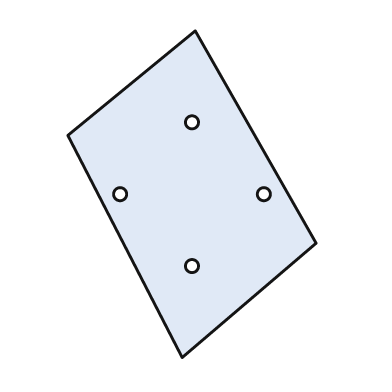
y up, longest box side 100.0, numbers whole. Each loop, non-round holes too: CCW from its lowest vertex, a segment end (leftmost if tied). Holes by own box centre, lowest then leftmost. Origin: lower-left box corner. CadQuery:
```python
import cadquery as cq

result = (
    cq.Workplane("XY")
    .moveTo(35.0, 0.0)
    .lineTo(76.0, 35.0)
    .lineTo(39.0, 100.0)
    .lineTo(0.0, 68.0)
    .close()
    .moveTo(38.0, 28.0)
    .circle(2.0)
    .moveTo(16.0, 50.0)
    .circle(2.0)
    .moveTo(60.0, 50.0)
    .circle(2.0)
    .moveTo(38.0, 72.0)
    .circle(2.0)
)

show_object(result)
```